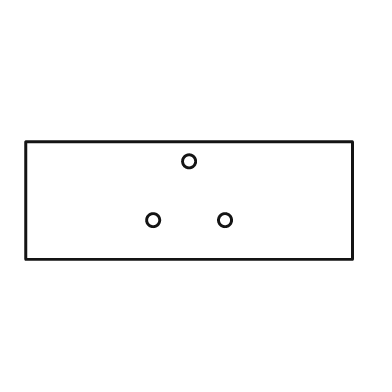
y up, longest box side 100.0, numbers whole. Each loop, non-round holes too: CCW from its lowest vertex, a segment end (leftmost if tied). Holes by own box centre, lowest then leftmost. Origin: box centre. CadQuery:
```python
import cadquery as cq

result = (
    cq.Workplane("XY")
    .moveTo(-50.0, -18.0)
    .lineTo(50.0, -18.0)
    .lineTo(50.0, 18.0)
    .lineTo(-50.0, 18.0)
    .close()
    .moveTo(-11.0, -6.0)
    .circle(2.0)
    .moveTo(11.0, -6.0)
    .circle(2.0)
    .moveTo(0.0, 12.0)
    .circle(2.0)
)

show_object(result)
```